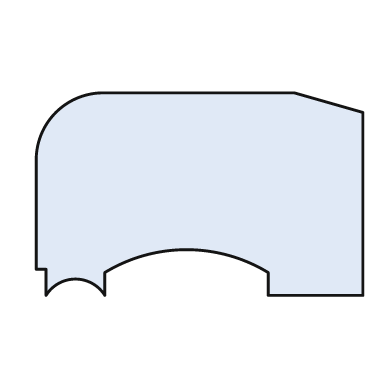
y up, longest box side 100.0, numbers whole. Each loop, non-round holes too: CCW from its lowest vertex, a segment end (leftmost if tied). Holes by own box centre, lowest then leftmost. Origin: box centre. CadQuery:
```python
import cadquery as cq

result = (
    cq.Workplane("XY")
    .moveTo(-47.0, -31.0)
    .threePointArc((-38.0, -26.0), (-29.0, -31.0))
    .lineTo(-29.0, -24.0)
    .threePointArc((-4.0, -17.0), (21.0, -24.0))
    .lineTo(21.0, -31.0)
    .lineTo(50.0, -31.0)
    .lineTo(50.0, 25.0)
    .lineTo(29.0, 31.0)
    .lineTo(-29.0, 31.0)
    .threePointArc((-44.0, 25.0), (-50.0, 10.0))
    .lineTo(-50.0, -23.0)
    .lineTo(-47.0, -23.0)
    .close()
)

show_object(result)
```